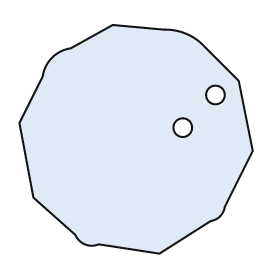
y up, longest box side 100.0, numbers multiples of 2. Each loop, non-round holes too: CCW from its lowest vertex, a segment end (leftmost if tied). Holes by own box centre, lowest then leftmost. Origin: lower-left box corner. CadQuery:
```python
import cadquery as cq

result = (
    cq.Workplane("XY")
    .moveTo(60.0, 0.0)
    .lineTo(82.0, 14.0)
    .threePointArc((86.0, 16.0), (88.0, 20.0))
    .lineTo(100.0, 44.0)
    .lineTo(94.0, 74.0)
    .lineTo(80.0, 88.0)
    .threePointArc((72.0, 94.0), (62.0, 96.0))
    .lineTo(40.0, 98.0)
    .lineTo(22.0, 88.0)
    .threePointArc((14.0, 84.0), (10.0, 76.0))
    .lineTo(0.0, 56.0)
    .lineTo(6.0, 24.0)
    .lineTo(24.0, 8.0)
    .threePointArc((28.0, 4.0), (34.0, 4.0))
    .close()
    .moveTo(70.0, 54.0)
    .circle(4.0)
    .moveTo(84.0, 68.0)
    .circle(4.0)
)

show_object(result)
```